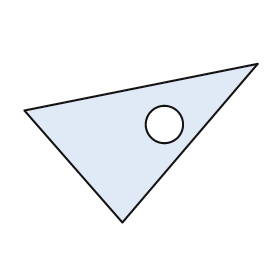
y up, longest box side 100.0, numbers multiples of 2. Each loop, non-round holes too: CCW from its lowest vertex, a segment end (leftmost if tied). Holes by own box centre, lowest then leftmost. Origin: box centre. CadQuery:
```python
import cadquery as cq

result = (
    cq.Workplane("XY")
    .moveTo(-8.0, -34.0)
    .lineTo(50.0, 34.0)
    .lineTo(-50.0, 14.0)
    .close()
    .moveTo(10.0, 8.0)
    .circle(8.0)
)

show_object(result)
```